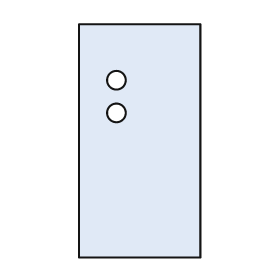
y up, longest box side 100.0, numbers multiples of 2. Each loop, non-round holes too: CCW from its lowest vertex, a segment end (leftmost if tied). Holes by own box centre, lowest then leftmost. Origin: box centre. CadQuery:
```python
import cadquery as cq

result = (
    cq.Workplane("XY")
    .moveTo(-26.0, -50.0)
    .lineTo(26.0, -50.0)
    .lineTo(26.0, 50.0)
    .lineTo(-26.0, 50.0)
    .close()
    .moveTo(-10.0, 12.0)
    .circle(4.0)
    .moveTo(-10.0, 26.0)
    .circle(4.0)
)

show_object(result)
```